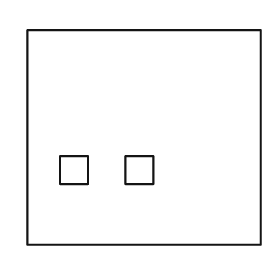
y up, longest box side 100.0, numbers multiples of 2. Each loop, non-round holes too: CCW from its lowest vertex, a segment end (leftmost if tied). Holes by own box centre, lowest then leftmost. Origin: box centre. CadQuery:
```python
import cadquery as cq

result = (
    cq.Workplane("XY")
    .moveTo(-50.0, -46.0)
    .lineTo(50.0, -46.0)
    .lineTo(50.0, 46.0)
    .lineTo(-50.0, 46.0)
    .close()
    .moveTo(-36.0, -20.0)
    .lineTo(-24.0, -20.0)
    .lineTo(-24.0, -8.0)
    .lineTo(-36.0, -8.0)
    .close()
    .moveTo(-8.0, -20.0)
    .lineTo(4.0, -20.0)
    .lineTo(4.0, -8.0)
    .lineTo(-8.0, -8.0)
    .close()
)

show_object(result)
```